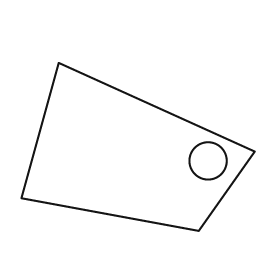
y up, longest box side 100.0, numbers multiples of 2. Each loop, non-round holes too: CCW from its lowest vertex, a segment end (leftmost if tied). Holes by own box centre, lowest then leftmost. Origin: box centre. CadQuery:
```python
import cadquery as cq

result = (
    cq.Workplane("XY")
    .moveTo(26.0, -36.0)
    .lineTo(50.0, -2.0)
    .lineTo(-34.0, 36.0)
    .lineTo(-50.0, -22.0)
    .close()
    .moveTo(30.0, -6.0)
    .circle(8.0)
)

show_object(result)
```